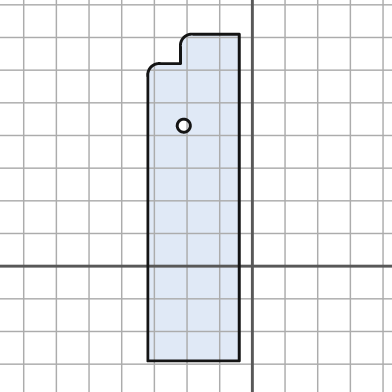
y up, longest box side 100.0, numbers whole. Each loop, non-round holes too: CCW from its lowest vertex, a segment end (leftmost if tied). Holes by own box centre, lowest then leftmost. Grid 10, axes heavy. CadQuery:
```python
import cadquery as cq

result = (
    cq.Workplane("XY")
    .moveTo(-32.0, -29.0)
    .lineTo(-4.0, -29.0)
    .lineTo(-4.0, 71.0)
    .lineTo(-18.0, 71.0)
    .threePointArc((-21.0, 70.0), (-22.0, 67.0))
    .lineTo(-22.0, 62.0)
    .lineTo(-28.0, 62.0)
    .threePointArc((-31.0, 61.0), (-32.0, 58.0))
    .close()
    .moveTo(-21.0, 43.0)
    .circle(2.0)
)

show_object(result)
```